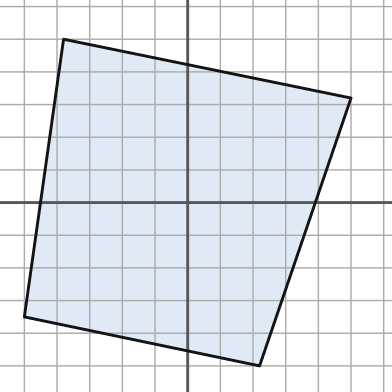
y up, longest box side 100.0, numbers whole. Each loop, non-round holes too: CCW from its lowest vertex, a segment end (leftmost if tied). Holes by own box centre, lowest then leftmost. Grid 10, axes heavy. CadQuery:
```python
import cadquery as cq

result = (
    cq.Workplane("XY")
    .moveTo(22.0, -50.0)
    .lineTo(50.0, 32.0)
    .lineTo(-38.0, 50.0)
    .lineTo(-50.0, -35.0)
    .close()
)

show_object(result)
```